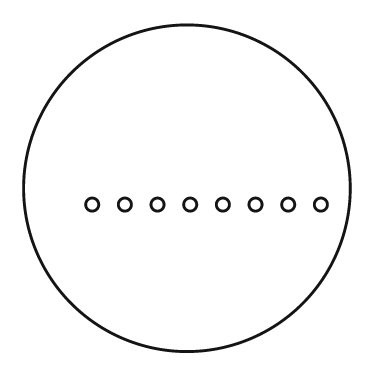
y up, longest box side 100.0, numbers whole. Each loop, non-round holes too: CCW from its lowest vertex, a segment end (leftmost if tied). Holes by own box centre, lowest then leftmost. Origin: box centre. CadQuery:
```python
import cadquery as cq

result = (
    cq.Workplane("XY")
    .moveTo(0.0, 0.0)
    .circle(50.0)
    .moveTo(-29.0, -5.0)
    .circle(2.0)
    .moveTo(-19.0, -5.0)
    .circle(2.0)
    .moveTo(-9.0, -5.0)
    .circle(2.0)
    .moveTo(1.0, -5.0)
    .circle(2.0)
    .moveTo(11.0, -5.0)
    .circle(2.0)
    .moveTo(21.0, -5.0)
    .circle(2.0)
    .moveTo(31.0, -5.0)
    .circle(2.0)
    .moveTo(41.0, -5.0)
    .circle(2.0)
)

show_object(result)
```